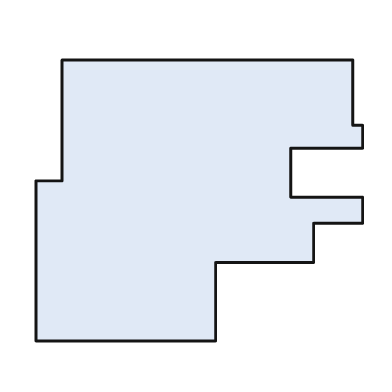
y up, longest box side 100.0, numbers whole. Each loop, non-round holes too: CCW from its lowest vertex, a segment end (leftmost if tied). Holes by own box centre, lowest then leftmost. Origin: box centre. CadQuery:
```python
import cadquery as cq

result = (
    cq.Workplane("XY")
    .moveTo(-50.0, -43.0)
    .lineTo(5.0, -43.0)
    .lineTo(5.0, -19.0)
    .lineTo(35.0, -19.0)
    .lineTo(35.0, -7.0)
    .lineTo(50.0, -7.0)
    .lineTo(50.0, 1.0)
    .lineTo(28.0, 1.0)
    .lineTo(28.0, 16.0)
    .lineTo(50.0, 16.0)
    .lineTo(50.0, 23.0)
    .lineTo(47.0, 23.0)
    .lineTo(47.0, 43.0)
    .lineTo(-42.0, 43.0)
    .lineTo(-42.0, 6.0)
    .lineTo(-50.0, 6.0)
    .close()
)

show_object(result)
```